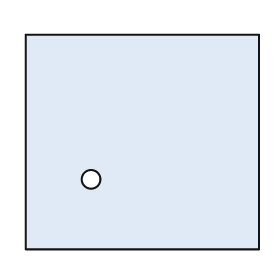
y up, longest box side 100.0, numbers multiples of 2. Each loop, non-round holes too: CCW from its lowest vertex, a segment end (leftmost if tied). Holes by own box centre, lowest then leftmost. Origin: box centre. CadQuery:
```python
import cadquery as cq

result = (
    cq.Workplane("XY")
    .moveTo(-50.0, -46.0)
    .lineTo(50.0, -46.0)
    .lineTo(50.0, 46.0)
    .lineTo(-50.0, 46.0)
    .close()
    .moveTo(-22.0, -16.0)
    .circle(4.0)
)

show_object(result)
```